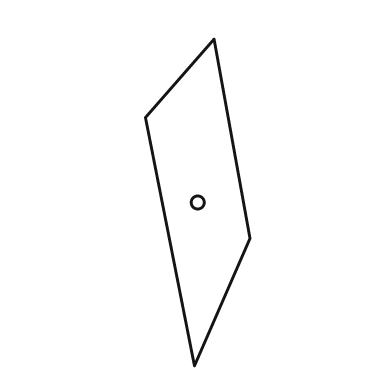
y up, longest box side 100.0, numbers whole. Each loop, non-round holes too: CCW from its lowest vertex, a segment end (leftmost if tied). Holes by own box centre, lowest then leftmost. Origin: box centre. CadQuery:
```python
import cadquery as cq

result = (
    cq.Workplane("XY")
    .moveTo(-1.0, -50.0)
    .lineTo(16.0, -11.0)
    .lineTo(5.0, 50.0)
    .lineTo(-16.0, 26.0)
    .close()
    .moveTo(0.0, 0.0)
    .circle(2.0)
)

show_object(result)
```